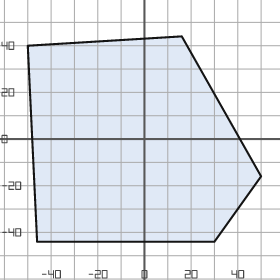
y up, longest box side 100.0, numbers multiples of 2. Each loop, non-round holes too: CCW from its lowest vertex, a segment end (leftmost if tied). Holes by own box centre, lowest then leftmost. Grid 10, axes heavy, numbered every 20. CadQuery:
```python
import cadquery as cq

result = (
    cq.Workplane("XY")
    .moveTo(-46.0, -44.0)
    .lineTo(30.0, -44.0)
    .lineTo(50.0, -16.0)
    .lineTo(16.0, 44.0)
    .lineTo(-50.0, 40.0)
    .close()
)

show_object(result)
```